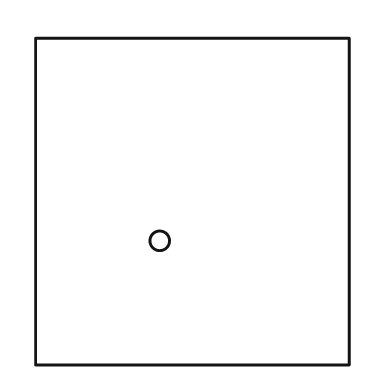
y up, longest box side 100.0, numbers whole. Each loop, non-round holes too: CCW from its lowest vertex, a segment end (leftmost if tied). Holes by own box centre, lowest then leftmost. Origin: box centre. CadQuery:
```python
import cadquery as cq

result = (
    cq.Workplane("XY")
    .moveTo(-48.0, -50.0)
    .lineTo(48.0, -50.0)
    .lineTo(48.0, 50.0)
    .lineTo(-48.0, 50.0)
    .close()
    .moveTo(-10.0, -12.0)
    .circle(3.0)
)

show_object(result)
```